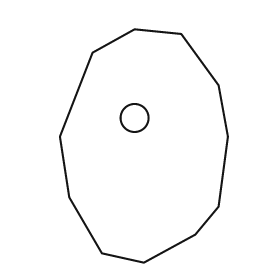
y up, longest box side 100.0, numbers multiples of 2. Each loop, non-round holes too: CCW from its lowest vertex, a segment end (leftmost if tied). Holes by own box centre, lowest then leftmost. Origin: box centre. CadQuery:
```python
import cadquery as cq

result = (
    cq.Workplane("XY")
    .moveTo(0.0, -50.0)
    .lineTo(22.0, -38.0)
    .lineTo(32.0, -26.0)
    .lineTo(36.0, 4.0)
    .lineTo(32.0, 26.0)
    .lineTo(16.0, 48.0)
    .lineTo(-4.0, 50.0)
    .lineTo(-22.0, 40.0)
    .lineTo(-36.0, 4.0)
    .lineTo(-32.0, -22.0)
    .lineTo(-18.0, -46.0)
    .close()
    .moveTo(-4.0, 12.0)
    .circle(6.0)
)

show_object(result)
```